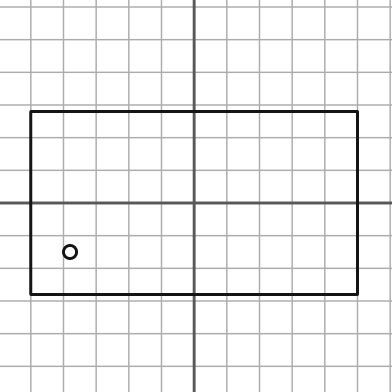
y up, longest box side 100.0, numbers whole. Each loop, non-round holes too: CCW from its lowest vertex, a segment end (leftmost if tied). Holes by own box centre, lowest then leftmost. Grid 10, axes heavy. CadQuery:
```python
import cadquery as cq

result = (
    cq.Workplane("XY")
    .moveTo(-50.0, -28.0)
    .lineTo(50.0, -28.0)
    .lineTo(50.0, 28.0)
    .lineTo(-50.0, 28.0)
    .close()
    .moveTo(-38.0, -15.0)
    .circle(2.0)
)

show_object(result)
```